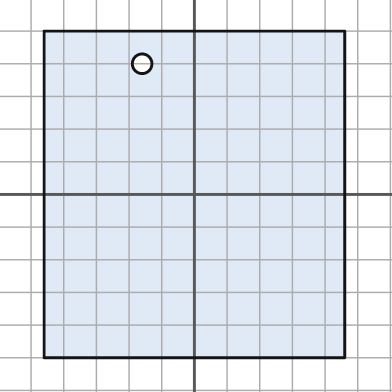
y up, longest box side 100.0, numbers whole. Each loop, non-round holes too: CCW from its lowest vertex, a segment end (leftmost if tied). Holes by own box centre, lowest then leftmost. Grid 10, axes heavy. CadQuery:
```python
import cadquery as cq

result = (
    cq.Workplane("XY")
    .moveTo(-46.0, -50.0)
    .lineTo(46.0, -50.0)
    .lineTo(46.0, 50.0)
    .lineTo(-46.0, 50.0)
    .close()
    .moveTo(-16.0, 40.0)
    .circle(3.0)
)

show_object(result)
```